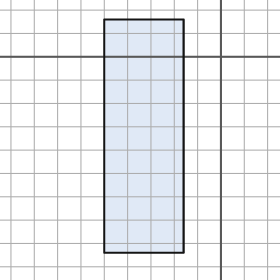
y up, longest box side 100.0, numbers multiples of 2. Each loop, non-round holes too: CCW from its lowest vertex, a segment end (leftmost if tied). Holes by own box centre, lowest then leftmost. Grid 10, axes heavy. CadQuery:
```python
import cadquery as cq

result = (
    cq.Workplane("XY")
    .moveTo(-50.0, -84.0)
    .lineTo(-16.0, -84.0)
    .lineTo(-16.0, 16.0)
    .lineTo(-50.0, 16.0)
    .close()
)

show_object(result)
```